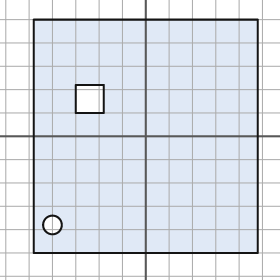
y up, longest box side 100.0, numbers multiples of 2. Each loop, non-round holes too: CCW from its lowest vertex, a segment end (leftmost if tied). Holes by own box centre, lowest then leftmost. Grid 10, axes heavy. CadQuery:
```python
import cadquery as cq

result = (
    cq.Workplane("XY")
    .moveTo(-48.0, -50.0)
    .lineTo(48.0, -50.0)
    .lineTo(48.0, 50.0)
    .lineTo(-48.0, 50.0)
    .close()
    .moveTo(-40.0, -38.0)
    .circle(4.0)
    .moveTo(-30.0, 10.0)
    .lineTo(-18.0, 10.0)
    .lineTo(-18.0, 22.0)
    .lineTo(-30.0, 22.0)
    .close()
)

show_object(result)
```